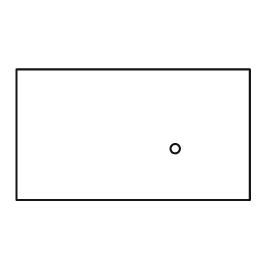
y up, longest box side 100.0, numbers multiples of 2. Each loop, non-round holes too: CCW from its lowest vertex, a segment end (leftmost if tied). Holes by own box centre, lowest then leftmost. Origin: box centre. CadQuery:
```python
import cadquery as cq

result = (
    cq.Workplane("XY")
    .moveTo(-50.0, -28.0)
    .lineTo(50.0, -28.0)
    .lineTo(50.0, 28.0)
    .lineTo(-50.0, 28.0)
    .close()
    .moveTo(18.0, -6.0)
    .circle(2.0)
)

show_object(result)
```